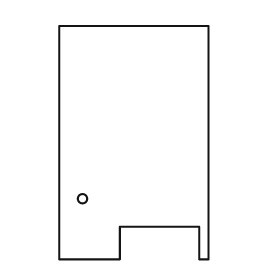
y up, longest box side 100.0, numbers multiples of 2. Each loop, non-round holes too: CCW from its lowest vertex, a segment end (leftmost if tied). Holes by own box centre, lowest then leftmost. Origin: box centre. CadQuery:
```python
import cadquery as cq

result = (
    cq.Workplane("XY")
    .moveTo(-32.0, -50.0)
    .lineTo(-6.0, -50.0)
    .lineTo(-6.0, -36.0)
    .lineTo(28.0, -36.0)
    .lineTo(28.0, -50.0)
    .lineTo(32.0, -50.0)
    .lineTo(32.0, 50.0)
    .lineTo(-32.0, 50.0)
    .close()
    .moveTo(-22.0, -24.0)
    .circle(2.0)
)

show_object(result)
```